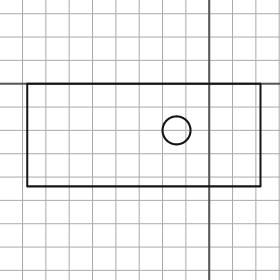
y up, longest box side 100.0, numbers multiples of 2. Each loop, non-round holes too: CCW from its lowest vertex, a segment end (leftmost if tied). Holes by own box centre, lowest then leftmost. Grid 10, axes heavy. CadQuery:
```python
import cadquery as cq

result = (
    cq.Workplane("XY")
    .moveTo(-78.0, -44.0)
    .lineTo(22.0, -44.0)
    .lineTo(22.0, 0.0)
    .lineTo(-78.0, 0.0)
    .close()
    .moveTo(-14.0, -20.0)
    .circle(6.0)
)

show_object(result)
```